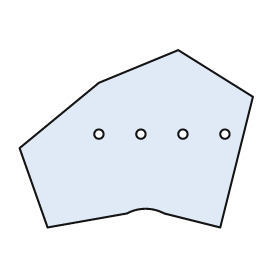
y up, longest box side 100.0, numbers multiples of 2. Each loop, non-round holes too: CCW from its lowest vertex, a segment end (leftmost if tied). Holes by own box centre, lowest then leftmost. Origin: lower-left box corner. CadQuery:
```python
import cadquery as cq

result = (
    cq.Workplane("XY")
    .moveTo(12.0, 0.0)
    .lineTo(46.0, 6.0)
    .threePointArc((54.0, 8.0), (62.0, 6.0))
    .lineTo(86.0, 0.0)
    .lineTo(100.0, 56.0)
    .lineTo(68.0, 76.0)
    .lineTo(34.0, 62.0)
    .lineTo(0.0, 34.0)
    .close()
    .moveTo(34.0, 40.0)
    .circle(2.0)
    .moveTo(52.0, 40.0)
    .circle(2.0)
    .moveTo(70.0, 40.0)
    .circle(2.0)
    .moveTo(88.0, 40.0)
    .circle(2.0)
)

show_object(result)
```